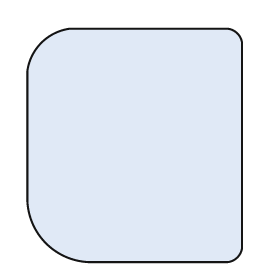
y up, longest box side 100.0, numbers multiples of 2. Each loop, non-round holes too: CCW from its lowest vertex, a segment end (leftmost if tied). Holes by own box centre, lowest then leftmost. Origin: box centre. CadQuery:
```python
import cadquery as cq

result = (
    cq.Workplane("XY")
    .moveTo(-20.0, -50.0)
    .lineTo(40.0, -50.0)
    .threePointArc((44.0, -48.0), (46.0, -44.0))
    .lineTo(46.0, 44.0)
    .threePointArc((44.0, 48.0), (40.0, 50.0))
    .lineTo(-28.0, 50.0)
    .threePointArc((-40.0, 44.0), (-46.0, 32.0))
    .lineTo(-46.0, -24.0)
    .threePointArc((-38.0, -42.0), (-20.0, -50.0))
    .close()
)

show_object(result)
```